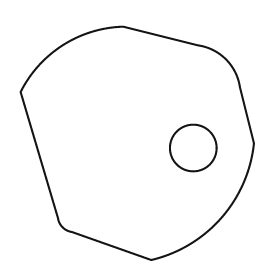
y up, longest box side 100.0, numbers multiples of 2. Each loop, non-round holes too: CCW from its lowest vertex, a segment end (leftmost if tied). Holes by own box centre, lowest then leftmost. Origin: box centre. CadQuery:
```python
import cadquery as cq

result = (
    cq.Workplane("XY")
    .moveTo(6.0, -50.0)
    .threePointArc((36.0, -32.0), (50.0, 0.0))
    .lineTo(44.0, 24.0)
    .threePointArc((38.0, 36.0), (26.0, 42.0))
    .lineTo(-6.0, 50.0)
    .threePointArc((-32.0, 42.0), (-50.0, 22.0))
    .lineTo(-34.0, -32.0)
    .threePointArc((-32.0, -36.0), (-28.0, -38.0))
    .close()
    .moveTo(24.0, -2.0)
    .circle(10.0)
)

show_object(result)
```